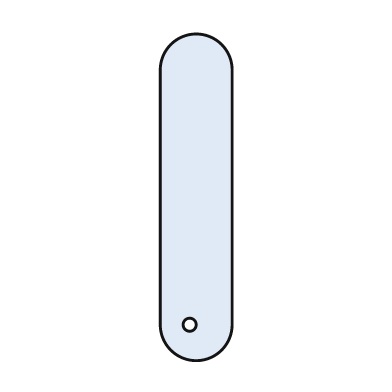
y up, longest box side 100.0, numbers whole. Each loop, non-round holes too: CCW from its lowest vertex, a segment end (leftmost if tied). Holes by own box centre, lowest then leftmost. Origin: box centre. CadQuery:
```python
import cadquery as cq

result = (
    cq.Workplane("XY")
    .moveTo(-11.0, -39.0)
    .threePointArc((0.0, -50.0), (11.0, -39.0))
    .lineTo(11.0, 39.0)
    .threePointArc((0.0, 50.0), (-11.0, 39.0))
    .close()
    .moveTo(-2.0, -39.0)
    .circle(2.0)
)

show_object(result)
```